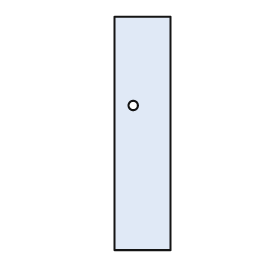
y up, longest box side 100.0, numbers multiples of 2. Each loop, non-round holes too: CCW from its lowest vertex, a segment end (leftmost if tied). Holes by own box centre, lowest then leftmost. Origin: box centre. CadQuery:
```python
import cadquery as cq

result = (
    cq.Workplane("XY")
    .moveTo(-12.0, -50.0)
    .lineTo(12.0, -50.0)
    .lineTo(12.0, 50.0)
    .lineTo(-12.0, 50.0)
    .close()
    .moveTo(-4.0, 12.0)
    .circle(2.0)
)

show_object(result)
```